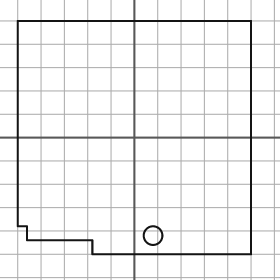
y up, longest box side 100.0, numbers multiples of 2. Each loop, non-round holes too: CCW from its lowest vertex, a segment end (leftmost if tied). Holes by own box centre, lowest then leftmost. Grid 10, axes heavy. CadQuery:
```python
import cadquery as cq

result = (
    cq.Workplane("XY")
    .moveTo(-18.0, -50.0)
    .lineTo(50.0, -50.0)
    .lineTo(50.0, 50.0)
    .lineTo(-50.0, 50.0)
    .lineTo(-50.0, -38.0)
    .lineTo(-46.0, -38.0)
    .lineTo(-46.0, -44.0)
    .lineTo(-18.0, -44.0)
    .close()
    .moveTo(8.0, -42.0)
    .circle(4.0)
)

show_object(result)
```